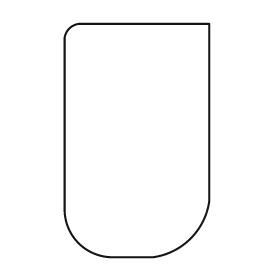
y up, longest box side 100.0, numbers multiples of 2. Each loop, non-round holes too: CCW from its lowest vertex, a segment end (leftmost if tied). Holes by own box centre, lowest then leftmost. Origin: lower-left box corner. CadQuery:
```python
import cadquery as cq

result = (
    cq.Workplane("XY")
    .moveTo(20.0, 0.0)
    .lineTo(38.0, 0.0)
    .threePointArc((54.0, 8.0), (62.0, 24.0))
    .lineTo(62.0, 100.0)
    .lineTo(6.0, 100.0)
    .threePointArc((2.0, 98.0), (0.0, 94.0))
    .lineTo(0.0, 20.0)
    .threePointArc((6.0, 6.0), (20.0, 0.0))
    .close()
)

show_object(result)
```